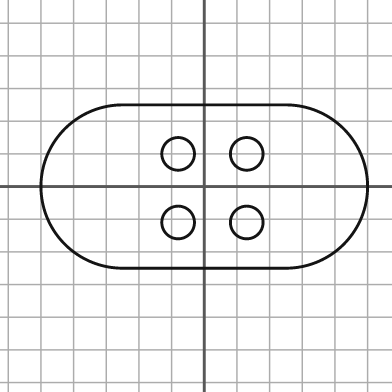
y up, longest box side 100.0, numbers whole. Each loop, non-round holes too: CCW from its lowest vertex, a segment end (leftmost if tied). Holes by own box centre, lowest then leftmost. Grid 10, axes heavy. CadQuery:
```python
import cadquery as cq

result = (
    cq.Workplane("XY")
    .moveTo(-25.0, -25.0)
    .lineTo(25.0, -25.0)
    .threePointArc((50.0, 0.0), (25.0, 25.0))
    .lineTo(-25.0, 25.0)
    .threePointArc((-50.0, 0.0), (-25.0, -25.0))
    .close()
    .moveTo(-8.0, -11.0)
    .circle(5.0)
    .moveTo(13.0, -11.0)
    .circle(5.0)
    .moveTo(-8.0, 10.0)
    .circle(5.0)
    .moveTo(13.0, 10.0)
    .circle(5.0)
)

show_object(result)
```